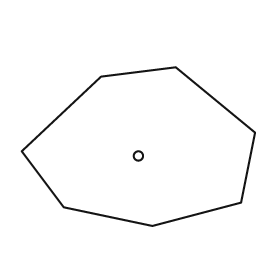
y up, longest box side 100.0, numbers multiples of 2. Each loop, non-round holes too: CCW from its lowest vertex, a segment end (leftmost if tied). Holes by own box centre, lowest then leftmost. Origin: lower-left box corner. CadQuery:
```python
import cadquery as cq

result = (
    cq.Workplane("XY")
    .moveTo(56.0, 0.0)
    .lineTo(94.0, 10.0)
    .lineTo(100.0, 40.0)
    .lineTo(66.0, 68.0)
    .lineTo(34.0, 64.0)
    .lineTo(0.0, 32.0)
    .lineTo(18.0, 8.0)
    .close()
    .moveTo(50.0, 30.0)
    .circle(2.0)
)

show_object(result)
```